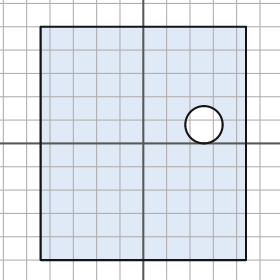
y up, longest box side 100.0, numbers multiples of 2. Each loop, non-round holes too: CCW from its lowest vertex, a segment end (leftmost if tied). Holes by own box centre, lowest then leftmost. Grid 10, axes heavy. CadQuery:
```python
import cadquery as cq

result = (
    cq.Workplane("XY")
    .moveTo(-44.0, -50.0)
    .lineTo(44.0, -50.0)
    .lineTo(44.0, 50.0)
    .lineTo(-44.0, 50.0)
    .close()
    .moveTo(26.0, 8.0)
    .circle(8.0)
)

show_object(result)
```